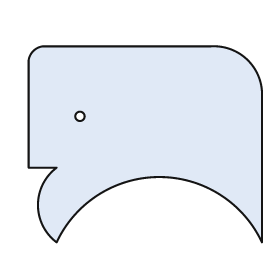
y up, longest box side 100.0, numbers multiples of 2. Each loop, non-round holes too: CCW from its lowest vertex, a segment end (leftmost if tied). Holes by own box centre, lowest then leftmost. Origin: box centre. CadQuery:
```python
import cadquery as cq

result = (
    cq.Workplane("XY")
    .moveTo(-38.0, -42.0)
    .threePointArc((6.0, -14.0), (50.0, -42.0))
    .lineTo(50.0, 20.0)
    .threePointArc((44.0, 36.0), (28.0, 42.0))
    .lineTo(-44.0, 42.0)
    .threePointArc((-48.0, 40.0), (-50.0, 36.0))
    .lineTo(-50.0, -10.0)
    .lineTo(-38.0, -10.0)
    .threePointArc((-46.0, -26.0), (-38.0, -42.0))
    .close()
    .moveTo(-28.0, 12.0)
    .circle(2.0)
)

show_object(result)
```